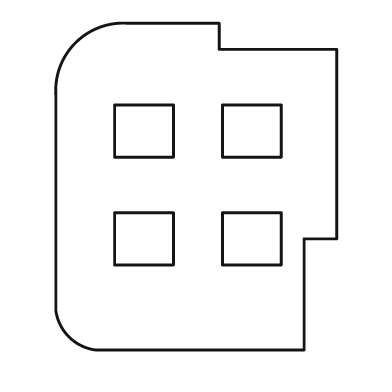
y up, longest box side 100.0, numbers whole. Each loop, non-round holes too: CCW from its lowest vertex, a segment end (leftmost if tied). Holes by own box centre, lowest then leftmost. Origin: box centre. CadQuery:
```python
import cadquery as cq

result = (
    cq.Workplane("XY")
    .moveTo(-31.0, -50.0)
    .lineTo(33.0, -50.0)
    .lineTo(33.0, -16.0)
    .lineTo(43.0, -16.0)
    .lineTo(43.0, 42.0)
    .lineTo(7.0, 42.0)
    .lineTo(7.0, 50.0)
    .lineTo(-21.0, 50.0)
    .threePointArc((-37.0, 44.0), (-43.0, 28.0))
    .lineTo(-43.0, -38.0)
    .threePointArc((-39.0, -46.0), (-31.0, -50.0))
    .close()
    .moveTo(-25.0, -24.0)
    .lineTo(-7.0, -24.0)
    .lineTo(-7.0, -8.0)
    .lineTo(-25.0, -8.0)
    .close()
    .moveTo(8.0, -24.0)
    .lineTo(26.0, -24.0)
    .lineTo(26.0, -8.0)
    .lineTo(8.0, -8.0)
    .close()
    .moveTo(-25.0, 9.0)
    .lineTo(-7.0, 9.0)
    .lineTo(-7.0, 25.0)
    .lineTo(-25.0, 25.0)
    .close()
    .moveTo(8.0, 9.0)
    .lineTo(26.0, 9.0)
    .lineTo(26.0, 25.0)
    .lineTo(8.0, 25.0)
    .close()
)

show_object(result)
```